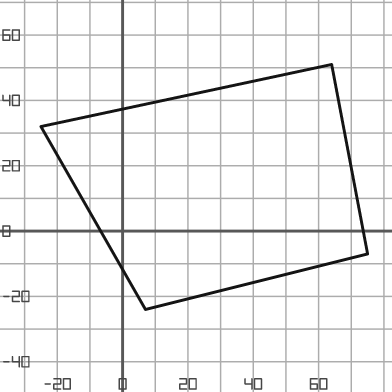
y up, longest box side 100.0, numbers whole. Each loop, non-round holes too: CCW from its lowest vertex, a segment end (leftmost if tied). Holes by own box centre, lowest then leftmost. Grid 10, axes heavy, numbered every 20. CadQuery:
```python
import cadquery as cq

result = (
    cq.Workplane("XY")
    .moveTo(7.0, -24.0)
    .lineTo(75.0, -7.0)
    .lineTo(64.0, 51.0)
    .lineTo(-25.0, 32.0)
    .close()
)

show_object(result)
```